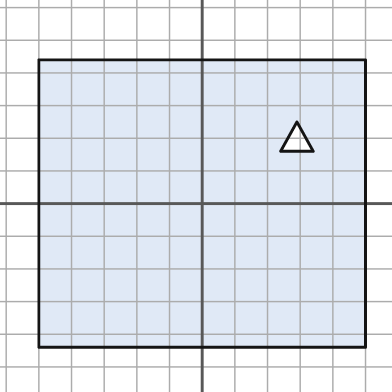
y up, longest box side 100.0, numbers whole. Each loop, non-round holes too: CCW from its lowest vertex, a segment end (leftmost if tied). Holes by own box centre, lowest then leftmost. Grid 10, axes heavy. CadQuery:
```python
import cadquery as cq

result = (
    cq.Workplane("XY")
    .moveTo(-50.0, -44.0)
    .lineTo(50.0, -44.0)
    .lineTo(50.0, 44.0)
    .lineTo(-50.0, 44.0)
    .close()
    .moveTo(24.0, 16.0)
    .lineTo(34.0, 16.0)
    .lineTo(29.0, 25.0)
    .close()
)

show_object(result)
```